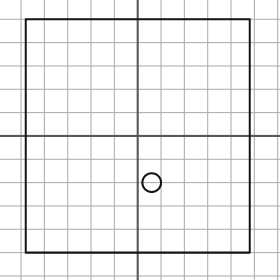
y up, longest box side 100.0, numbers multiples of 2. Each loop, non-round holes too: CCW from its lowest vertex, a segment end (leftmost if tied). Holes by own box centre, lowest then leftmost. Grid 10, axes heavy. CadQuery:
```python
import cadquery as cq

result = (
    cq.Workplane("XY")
    .moveTo(-48.0, -50.0)
    .lineTo(48.0, -50.0)
    .lineTo(48.0, 50.0)
    .lineTo(-48.0, 50.0)
    .close()
    .moveTo(6.0, -20.0)
    .circle(4.0)
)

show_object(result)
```